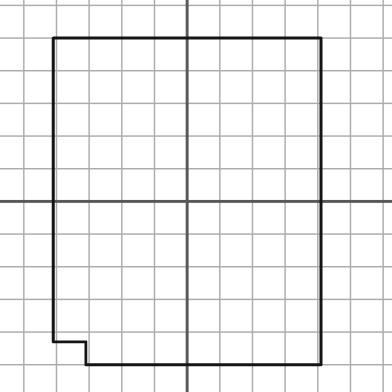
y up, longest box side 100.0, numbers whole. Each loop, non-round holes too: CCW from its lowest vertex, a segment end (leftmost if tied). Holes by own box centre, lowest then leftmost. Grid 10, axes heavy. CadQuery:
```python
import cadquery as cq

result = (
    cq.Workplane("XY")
    .moveTo(-31.0, -50.0)
    .lineTo(41.0, -50.0)
    .lineTo(41.0, 50.0)
    .lineTo(-41.0, 50.0)
    .lineTo(-41.0, -43.0)
    .lineTo(-31.0, -43.0)
    .close()
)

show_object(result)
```